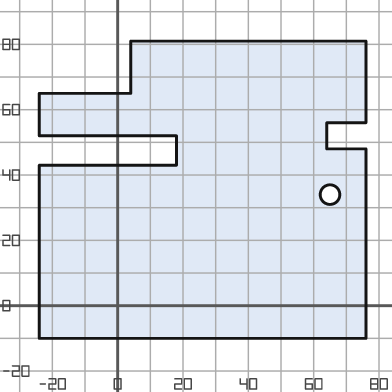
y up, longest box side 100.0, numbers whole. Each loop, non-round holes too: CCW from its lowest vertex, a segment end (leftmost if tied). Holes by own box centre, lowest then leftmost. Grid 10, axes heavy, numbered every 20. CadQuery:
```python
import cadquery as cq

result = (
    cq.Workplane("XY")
    .moveTo(-24.0, -10.0)
    .lineTo(76.0, -10.0)
    .lineTo(76.0, 48.0)
    .lineTo(64.0, 48.0)
    .lineTo(64.0, 56.0)
    .lineTo(76.0, 56.0)
    .lineTo(76.0, 81.0)
    .lineTo(4.0, 81.0)
    .lineTo(4.0, 65.0)
    .lineTo(-24.0, 65.0)
    .lineTo(-24.0, 52.0)
    .lineTo(18.0, 52.0)
    .lineTo(18.0, 43.0)
    .lineTo(-24.0, 43.0)
    .close()
    .moveTo(65.0, 34.0)
    .circle(3.0)
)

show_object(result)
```